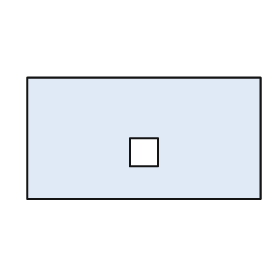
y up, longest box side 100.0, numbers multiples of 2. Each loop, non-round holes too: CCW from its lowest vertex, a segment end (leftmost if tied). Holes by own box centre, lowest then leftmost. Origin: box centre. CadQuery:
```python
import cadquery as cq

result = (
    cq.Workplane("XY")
    .moveTo(-50.0, -26.0)
    .lineTo(50.0, -26.0)
    .lineTo(50.0, 26.0)
    .lineTo(-50.0, 26.0)
    .close()
    .moveTo(-6.0, -12.0)
    .lineTo(6.0, -12.0)
    .lineTo(6.0, 0.0)
    .lineTo(-6.0, 0.0)
    .close()
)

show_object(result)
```